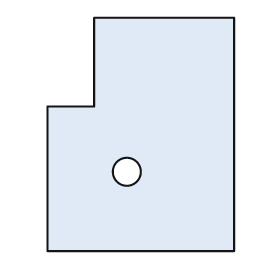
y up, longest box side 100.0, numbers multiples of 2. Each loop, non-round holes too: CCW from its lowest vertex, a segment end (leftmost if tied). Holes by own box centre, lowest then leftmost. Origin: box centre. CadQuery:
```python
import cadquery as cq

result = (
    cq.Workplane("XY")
    .moveTo(-40.0, -50.0)
    .lineTo(40.0, -50.0)
    .lineTo(40.0, 50.0)
    .lineTo(-20.0, 50.0)
    .lineTo(-20.0, 12.0)
    .lineTo(-40.0, 12.0)
    .close()
    .moveTo(-6.0, -16.0)
    .circle(6.0)
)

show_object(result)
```